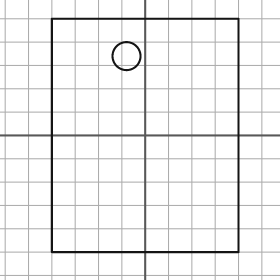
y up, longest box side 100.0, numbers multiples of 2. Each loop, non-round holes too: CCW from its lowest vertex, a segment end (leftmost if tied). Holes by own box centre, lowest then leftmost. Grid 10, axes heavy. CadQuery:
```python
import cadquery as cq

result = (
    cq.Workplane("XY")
    .moveTo(-40.0, -50.0)
    .lineTo(40.0, -50.0)
    .lineTo(40.0, 50.0)
    .lineTo(-40.0, 50.0)
    .close()
    .moveTo(-8.0, 34.0)
    .circle(6.0)
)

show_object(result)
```